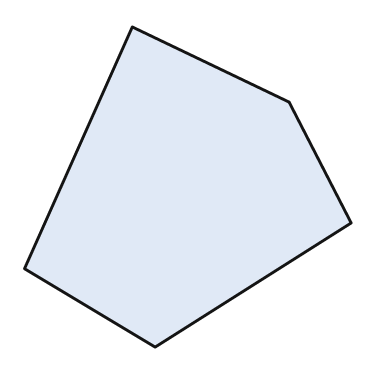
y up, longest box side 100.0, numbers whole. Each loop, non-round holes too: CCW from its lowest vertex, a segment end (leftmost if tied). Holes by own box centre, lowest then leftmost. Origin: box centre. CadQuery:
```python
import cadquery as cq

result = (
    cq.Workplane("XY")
    .moveTo(-10.0, -49.0)
    .lineTo(50.0, -11.0)
    .lineTo(31.0, 26.0)
    .lineTo(-17.0, 49.0)
    .lineTo(-50.0, -25.0)
    .close()
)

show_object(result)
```